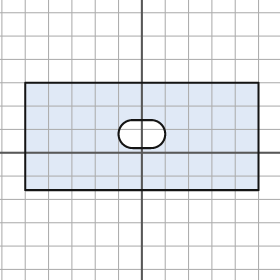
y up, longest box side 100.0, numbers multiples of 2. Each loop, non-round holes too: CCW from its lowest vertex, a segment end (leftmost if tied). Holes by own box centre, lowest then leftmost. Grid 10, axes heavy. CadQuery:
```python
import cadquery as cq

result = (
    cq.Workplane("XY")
    .moveTo(-50.0, -16.0)
    .lineTo(50.0, -16.0)
    .lineTo(50.0, 30.0)
    .lineTo(-50.0, 30.0)
    .close()
    .moveTo(-4.0, 2.0)
    .lineTo(4.0, 2.0)
    .threePointArc((10.0, 8.0), (4.0, 14.0))
    .lineTo(-4.0, 14.0)
    .threePointArc((-10.0, 8.0), (-4.0, 2.0))
    .close()
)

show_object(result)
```